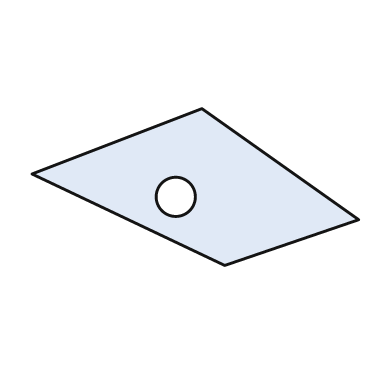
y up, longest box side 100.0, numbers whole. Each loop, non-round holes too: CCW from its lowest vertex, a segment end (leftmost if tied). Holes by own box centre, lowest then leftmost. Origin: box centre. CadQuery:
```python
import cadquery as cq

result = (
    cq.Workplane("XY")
    .moveTo(9.0, -24.0)
    .lineTo(50.0, -10.0)
    .lineTo(2.0, 24.0)
    .lineTo(-50.0, 4.0)
    .close()
    .moveTo(-6.0, -3.0)
    .circle(6.0)
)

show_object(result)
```